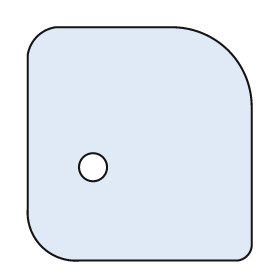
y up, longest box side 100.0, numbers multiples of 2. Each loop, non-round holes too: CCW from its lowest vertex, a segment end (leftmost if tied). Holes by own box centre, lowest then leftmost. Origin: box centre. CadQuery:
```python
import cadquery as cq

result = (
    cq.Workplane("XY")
    .moveTo(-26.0, -50.0)
    .lineTo(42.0, -50.0)
    .threePointArc((46.0, -48.0), (48.0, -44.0))
    .lineTo(48.0, 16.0)
    .threePointArc((38.0, 40.0), (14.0, 50.0))
    .lineTo(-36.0, 50.0)
    .threePointArc((-44.0, 46.0), (-48.0, 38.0))
    .lineTo(-48.0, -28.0)
    .threePointArc((-42.0, -44.0), (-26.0, -50.0))
    .close()
    .moveTo(-20.0, -10.0)
    .circle(6.0)
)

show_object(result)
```